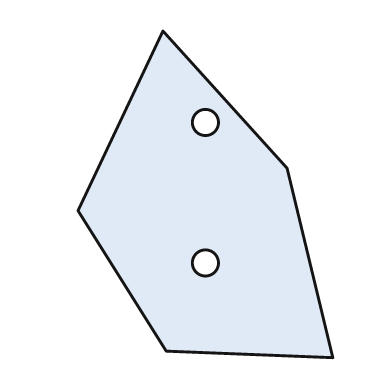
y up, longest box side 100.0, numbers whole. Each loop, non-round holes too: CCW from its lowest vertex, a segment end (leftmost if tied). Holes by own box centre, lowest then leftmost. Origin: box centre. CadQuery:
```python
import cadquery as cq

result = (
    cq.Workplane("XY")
    .moveTo(39.0, -50.0)
    .lineTo(25.0, 8.0)
    .lineTo(-13.0, 50.0)
    .lineTo(-39.0, -5.0)
    .lineTo(-12.0, -48.0)
    .close()
    .moveTo(0.0, -21.0)
    .circle(4.0)
    .moveTo(0.0, 22.0)
    .circle(4.0)
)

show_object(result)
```